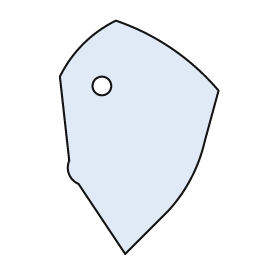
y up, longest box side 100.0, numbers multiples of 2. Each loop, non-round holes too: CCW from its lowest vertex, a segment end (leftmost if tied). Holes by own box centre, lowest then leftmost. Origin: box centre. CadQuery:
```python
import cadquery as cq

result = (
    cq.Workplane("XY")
    .moveTo(-6.0, -50.0)
    .lineTo(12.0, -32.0)
    .threePointArc((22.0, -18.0), (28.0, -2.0))
    .lineTo(34.0, 20.0)
    .threePointArc((14.0, 38.0), (-10.0, 50.0))
    .threePointArc((-24.0, 40.0), (-34.0, 26.0))
    .lineTo(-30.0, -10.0)
    .threePointArc((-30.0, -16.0), (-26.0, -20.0))
    .close()
    .moveTo(-16.0, 22.0)
    .circle(4.0)
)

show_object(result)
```